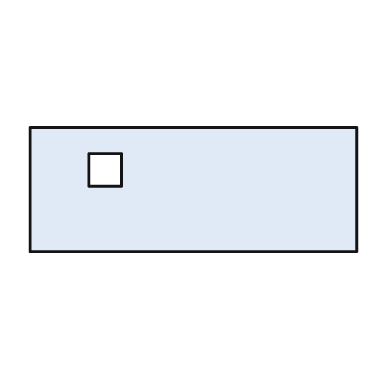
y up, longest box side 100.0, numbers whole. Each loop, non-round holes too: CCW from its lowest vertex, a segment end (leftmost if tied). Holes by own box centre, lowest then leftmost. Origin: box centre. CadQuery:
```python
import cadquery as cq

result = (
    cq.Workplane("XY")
    .moveTo(-50.0, -19.0)
    .lineTo(50.0, -19.0)
    .lineTo(50.0, 19.0)
    .lineTo(-50.0, 19.0)
    .close()
    .moveTo(-32.0, 1.0)
    .lineTo(-22.0, 1.0)
    .lineTo(-22.0, 11.0)
    .lineTo(-32.0, 11.0)
    .close()
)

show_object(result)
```